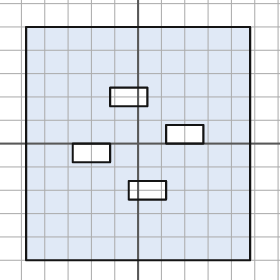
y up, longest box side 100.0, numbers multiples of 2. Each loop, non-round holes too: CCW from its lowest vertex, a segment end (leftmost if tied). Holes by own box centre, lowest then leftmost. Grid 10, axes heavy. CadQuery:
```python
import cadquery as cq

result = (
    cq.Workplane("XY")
    .moveTo(-48.0, -50.0)
    .lineTo(48.0, -50.0)
    .lineTo(48.0, 50.0)
    .lineTo(-48.0, 50.0)
    .close()
    .moveTo(-4.0, -24.0)
    .lineTo(12.0, -24.0)
    .lineTo(12.0, -16.0)
    .lineTo(-4.0, -16.0)
    .close()
    .moveTo(-28.0, -8.0)
    .lineTo(-12.0, -8.0)
    .lineTo(-12.0, 0.0)
    .lineTo(-28.0, 0.0)
    .close()
    .moveTo(12.0, 0.0)
    .lineTo(28.0, 0.0)
    .lineTo(28.0, 8.0)
    .lineTo(12.0, 8.0)
    .close()
    .moveTo(-12.0, 16.0)
    .lineTo(4.0, 16.0)
    .lineTo(4.0, 24.0)
    .lineTo(-12.0, 24.0)
    .close()
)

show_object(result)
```